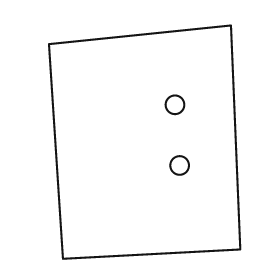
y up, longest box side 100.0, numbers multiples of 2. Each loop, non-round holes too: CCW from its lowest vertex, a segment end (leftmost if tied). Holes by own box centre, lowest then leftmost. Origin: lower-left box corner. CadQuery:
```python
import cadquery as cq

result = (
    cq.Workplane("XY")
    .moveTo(6.0, 0.0)
    .lineTo(82.0, 4.0)
    .lineTo(78.0, 100.0)
    .lineTo(0.0, 92.0)
    .close()
    .moveTo(56.0, 40.0)
    .circle(4.0)
    .moveTo(54.0, 66.0)
    .circle(4.0)
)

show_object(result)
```